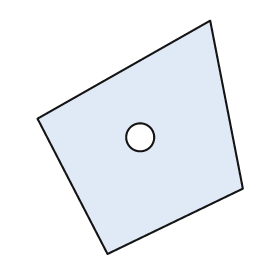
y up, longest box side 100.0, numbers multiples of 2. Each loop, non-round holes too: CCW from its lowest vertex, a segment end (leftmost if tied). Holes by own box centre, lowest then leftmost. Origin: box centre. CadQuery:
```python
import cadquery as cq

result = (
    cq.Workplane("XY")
    .moveTo(-14.0, -50.0)
    .lineTo(44.0, -22.0)
    .lineTo(30.0, 50.0)
    .lineTo(-44.0, 8.0)
    .close()
    .moveTo(0.0, 0.0)
    .circle(6.0)
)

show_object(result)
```